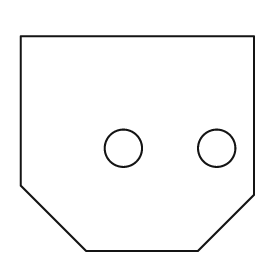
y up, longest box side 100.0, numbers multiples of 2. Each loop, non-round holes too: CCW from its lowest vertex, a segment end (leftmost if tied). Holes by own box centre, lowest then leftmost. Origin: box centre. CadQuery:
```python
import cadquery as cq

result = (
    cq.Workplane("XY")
    .moveTo(-22.0, -46.0)
    .lineTo(26.0, -46.0)
    .lineTo(50.0, -22.0)
    .lineTo(50.0, 46.0)
    .lineTo(-50.0, 46.0)
    .lineTo(-50.0, -18.0)
    .close()
    .moveTo(-6.0, -2.0)
    .circle(8.0)
    .moveTo(34.0, -2.0)
    .circle(8.0)
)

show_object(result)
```